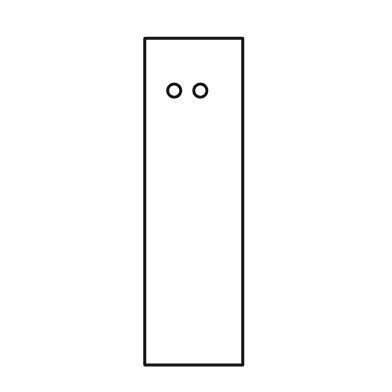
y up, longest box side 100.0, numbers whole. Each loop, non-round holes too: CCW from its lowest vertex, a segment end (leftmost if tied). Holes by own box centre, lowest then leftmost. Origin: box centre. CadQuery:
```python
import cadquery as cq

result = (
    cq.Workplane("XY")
    .moveTo(-15.0, -50.0)
    .lineTo(15.0, -50.0)
    .lineTo(15.0, 50.0)
    .lineTo(-15.0, 50.0)
    .close()
    .moveTo(-6.0, 34.0)
    .circle(2.0)
    .moveTo(2.0, 34.0)
    .circle(2.0)
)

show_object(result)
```